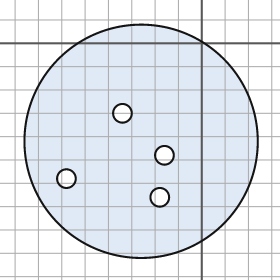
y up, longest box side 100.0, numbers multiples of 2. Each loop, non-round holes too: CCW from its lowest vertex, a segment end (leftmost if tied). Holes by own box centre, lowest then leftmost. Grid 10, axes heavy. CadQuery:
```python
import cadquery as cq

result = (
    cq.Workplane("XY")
    .moveTo(-26.0, -42.0)
    .circle(50.0)
    .moveTo(-18.0, -66.0)
    .circle(4.0)
    .moveTo(-58.0, -58.0)
    .circle(4.0)
    .moveTo(-16.0, -48.0)
    .circle(4.0)
    .moveTo(-34.0, -30.0)
    .circle(4.0)
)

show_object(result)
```